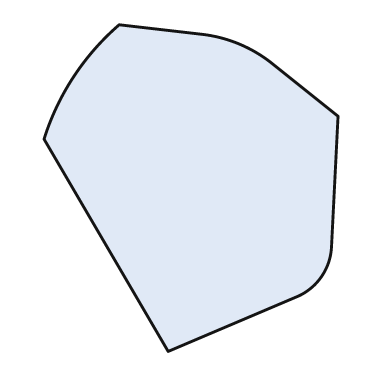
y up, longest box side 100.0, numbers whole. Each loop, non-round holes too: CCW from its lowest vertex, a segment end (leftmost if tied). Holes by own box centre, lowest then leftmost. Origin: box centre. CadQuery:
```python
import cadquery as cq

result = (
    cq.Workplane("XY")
    .moveTo(-7.0, -50.0)
    .lineTo(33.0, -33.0)
    .threePointArc((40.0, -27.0), (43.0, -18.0))
    .lineTo(45.0, 22.0)
    .lineTo(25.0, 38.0)
    .threePointArc((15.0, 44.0), (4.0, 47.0))
    .lineTo(-22.0, 50.0)
    .threePointArc((-36.0, 34.0), (-45.0, 15.0))
    .close()
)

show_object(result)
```